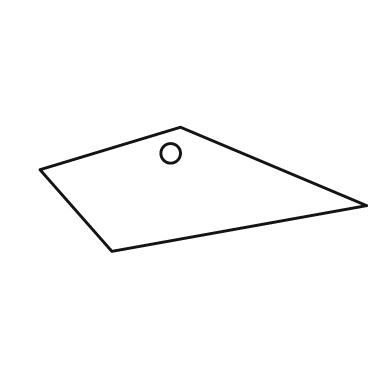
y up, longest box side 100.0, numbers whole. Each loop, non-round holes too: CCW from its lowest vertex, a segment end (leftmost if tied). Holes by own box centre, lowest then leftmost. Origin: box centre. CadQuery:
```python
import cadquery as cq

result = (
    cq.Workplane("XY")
    .moveTo(-28.0, -19.0)
    .lineTo(50.0, -5.0)
    .lineTo(-7.0, 19.0)
    .lineTo(-50.0, 6.0)
    .close()
    .moveTo(-10.0, 11.0)
    .circle(3.0)
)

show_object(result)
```